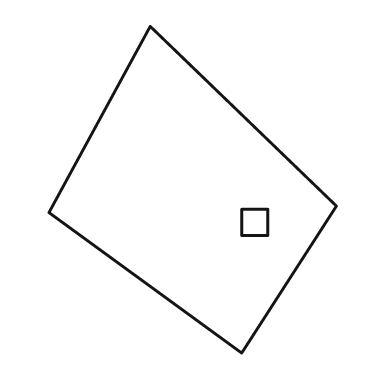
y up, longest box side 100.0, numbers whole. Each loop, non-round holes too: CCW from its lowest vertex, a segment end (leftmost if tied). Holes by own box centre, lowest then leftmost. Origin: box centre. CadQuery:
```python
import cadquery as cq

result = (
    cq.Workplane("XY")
    .moveTo(15.0, -50.0)
    .lineTo(44.0, -5.0)
    .lineTo(-13.0, 50.0)
    .lineTo(-44.0, -7.0)
    .close()
    .moveTo(15.0, -14.0)
    .lineTo(23.0, -14.0)
    .lineTo(23.0, -6.0)
    .lineTo(15.0, -6.0)
    .close()
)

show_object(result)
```